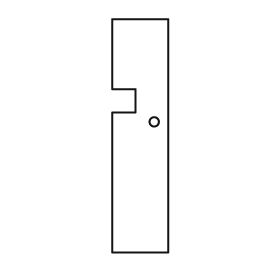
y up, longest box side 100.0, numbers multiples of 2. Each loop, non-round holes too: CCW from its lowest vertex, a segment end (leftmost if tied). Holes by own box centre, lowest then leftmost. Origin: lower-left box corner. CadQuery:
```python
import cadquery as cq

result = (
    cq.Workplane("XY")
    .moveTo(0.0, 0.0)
    .lineTo(24.0, 0.0)
    .lineTo(24.0, 100.0)
    .lineTo(0.0, 100.0)
    .lineTo(0.0, 70.0)
    .lineTo(10.0, 70.0)
    .lineTo(10.0, 60.0)
    .lineTo(0.0, 60.0)
    .close()
    .moveTo(18.0, 56.0)
    .circle(2.0)
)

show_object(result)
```